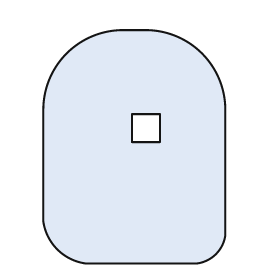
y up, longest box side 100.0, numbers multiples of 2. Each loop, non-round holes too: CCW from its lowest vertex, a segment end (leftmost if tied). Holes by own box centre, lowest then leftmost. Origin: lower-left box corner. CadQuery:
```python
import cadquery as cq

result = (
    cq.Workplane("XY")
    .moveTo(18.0, 0.0)
    .lineTo(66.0, 0.0)
    .threePointArc((74.0, 4.0), (78.0, 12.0))
    .lineTo(78.0, 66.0)
    .threePointArc((68.0, 90.0), (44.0, 100.0))
    .lineTo(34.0, 100.0)
    .threePointArc((10.0, 90.0), (0.0, 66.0))
    .lineTo(0.0, 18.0)
    .threePointArc((6.0, 6.0), (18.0, 0.0))
    .close()
    .moveTo(38.0, 52.0)
    .lineTo(50.0, 52.0)
    .lineTo(50.0, 64.0)
    .lineTo(38.0, 64.0)
    .close()
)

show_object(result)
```